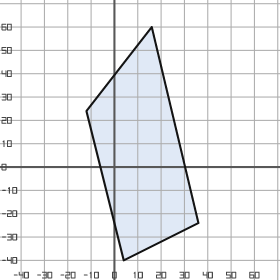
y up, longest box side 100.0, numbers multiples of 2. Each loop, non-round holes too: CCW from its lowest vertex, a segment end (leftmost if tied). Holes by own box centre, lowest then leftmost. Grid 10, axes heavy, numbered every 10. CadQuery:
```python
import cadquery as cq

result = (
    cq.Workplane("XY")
    .moveTo(4.0, -40.0)
    .lineTo(36.0, -24.0)
    .lineTo(16.0, 60.0)
    .lineTo(-12.0, 24.0)
    .close()
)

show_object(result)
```